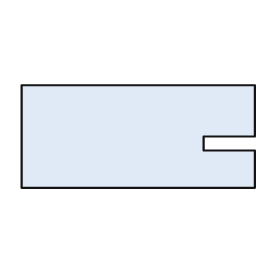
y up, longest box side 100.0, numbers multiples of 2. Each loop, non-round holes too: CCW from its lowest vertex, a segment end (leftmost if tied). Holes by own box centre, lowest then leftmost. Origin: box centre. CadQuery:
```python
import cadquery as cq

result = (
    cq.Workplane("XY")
    .moveTo(-50.0, -22.0)
    .lineTo(50.0, -22.0)
    .lineTo(50.0, -6.0)
    .lineTo(28.0, -6.0)
    .lineTo(28.0, 0.0)
    .lineTo(50.0, 0.0)
    .lineTo(50.0, 22.0)
    .lineTo(-50.0, 22.0)
    .close()
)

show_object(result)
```